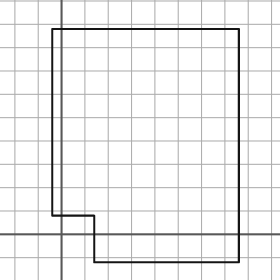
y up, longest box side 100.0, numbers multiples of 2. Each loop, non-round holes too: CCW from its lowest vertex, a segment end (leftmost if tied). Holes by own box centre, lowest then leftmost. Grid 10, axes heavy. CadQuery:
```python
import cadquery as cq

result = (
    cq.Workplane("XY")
    .moveTo(14.0, -12.0)
    .lineTo(76.0, -12.0)
    .lineTo(76.0, 88.0)
    .lineTo(-4.0, 88.0)
    .lineTo(-4.0, 8.0)
    .lineTo(14.0, 8.0)
    .close()
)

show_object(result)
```